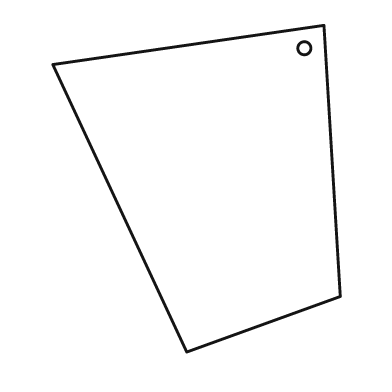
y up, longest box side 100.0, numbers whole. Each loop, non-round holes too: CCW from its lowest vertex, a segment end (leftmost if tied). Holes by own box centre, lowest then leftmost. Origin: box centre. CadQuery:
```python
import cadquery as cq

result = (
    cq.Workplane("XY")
    .moveTo(-3.0, -50.0)
    .lineTo(44.0, -33.0)
    .lineTo(39.0, 50.0)
    .lineTo(-44.0, 38.0)
    .close()
    .moveTo(33.0, 43.0)
    .circle(2.0)
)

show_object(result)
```